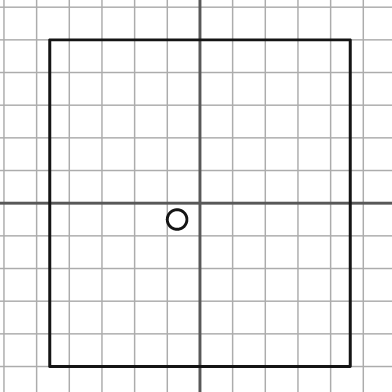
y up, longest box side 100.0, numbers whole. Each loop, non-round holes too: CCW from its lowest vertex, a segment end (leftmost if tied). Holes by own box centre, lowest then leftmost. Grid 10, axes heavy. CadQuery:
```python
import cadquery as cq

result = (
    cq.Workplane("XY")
    .moveTo(-46.0, -50.0)
    .lineTo(46.0, -50.0)
    .lineTo(46.0, 50.0)
    .lineTo(-46.0, 50.0)
    .close()
    .moveTo(-7.0, -5.0)
    .circle(3.0)
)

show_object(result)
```